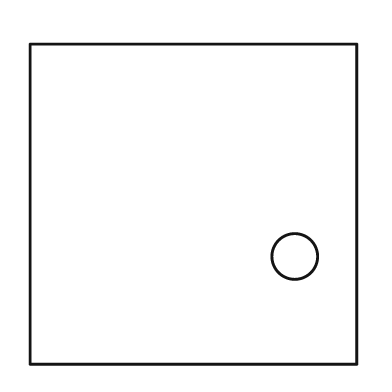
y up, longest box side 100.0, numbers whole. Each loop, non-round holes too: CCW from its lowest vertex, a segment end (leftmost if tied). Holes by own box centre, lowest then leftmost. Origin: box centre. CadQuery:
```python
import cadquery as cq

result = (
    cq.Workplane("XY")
    .moveTo(-50.0, -49.0)
    .lineTo(50.0, -49.0)
    .lineTo(50.0, 49.0)
    .lineTo(-50.0, 49.0)
    .close()
    .moveTo(31.0, -16.0)
    .circle(7.0)
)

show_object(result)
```